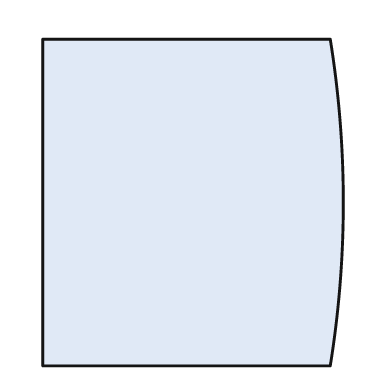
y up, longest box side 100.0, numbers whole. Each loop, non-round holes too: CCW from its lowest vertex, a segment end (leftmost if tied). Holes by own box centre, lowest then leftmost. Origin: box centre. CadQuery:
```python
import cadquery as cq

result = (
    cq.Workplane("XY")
    .moveTo(-46.0, -50.0)
    .lineTo(42.0, -50.0)
    .threePointArc((46.0, 0.0), (42.0, 50.0))
    .lineTo(-46.0, 50.0)
    .close()
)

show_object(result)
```